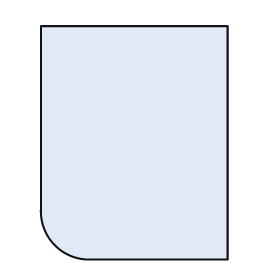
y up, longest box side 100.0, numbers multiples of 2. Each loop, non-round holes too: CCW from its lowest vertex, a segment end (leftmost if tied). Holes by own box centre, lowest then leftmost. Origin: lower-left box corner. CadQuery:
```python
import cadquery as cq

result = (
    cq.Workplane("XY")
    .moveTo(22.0, 0.0)
    .lineTo(80.0, 0.0)
    .lineTo(80.0, 100.0)
    .lineTo(0.0, 100.0)
    .lineTo(0.0, 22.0)
    .threePointArc((6.0, 6.0), (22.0, 0.0))
    .close()
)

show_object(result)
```